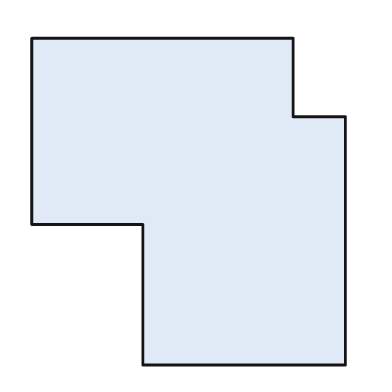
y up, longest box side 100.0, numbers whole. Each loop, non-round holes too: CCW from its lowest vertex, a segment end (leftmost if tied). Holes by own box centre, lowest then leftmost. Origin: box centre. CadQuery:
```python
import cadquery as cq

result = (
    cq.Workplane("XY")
    .moveTo(-14.0, -50.0)
    .lineTo(48.0, -50.0)
    .lineTo(48.0, 26.0)
    .lineTo(32.0, 26.0)
    .lineTo(32.0, 50.0)
    .lineTo(-48.0, 50.0)
    .lineTo(-48.0, -7.0)
    .lineTo(-14.0, -7.0)
    .close()
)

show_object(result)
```